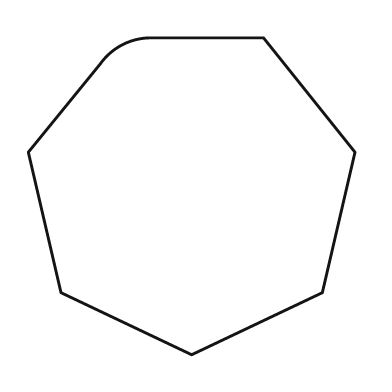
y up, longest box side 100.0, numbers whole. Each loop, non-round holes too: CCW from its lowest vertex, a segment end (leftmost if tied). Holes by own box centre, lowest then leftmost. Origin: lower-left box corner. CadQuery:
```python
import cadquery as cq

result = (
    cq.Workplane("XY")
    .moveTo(50.0, 0.0)
    .lineTo(90.0, 19.0)
    .lineTo(100.0, 62.0)
    .lineTo(72.0, 97.0)
    .lineTo(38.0, 97.0)
    .threePointArc((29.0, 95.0), (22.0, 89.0))
    .lineTo(0.0, 62.0)
    .lineTo(10.0, 19.0)
    .close()
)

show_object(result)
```